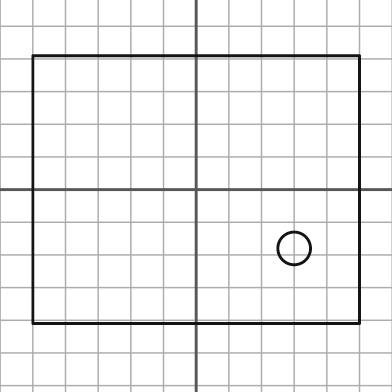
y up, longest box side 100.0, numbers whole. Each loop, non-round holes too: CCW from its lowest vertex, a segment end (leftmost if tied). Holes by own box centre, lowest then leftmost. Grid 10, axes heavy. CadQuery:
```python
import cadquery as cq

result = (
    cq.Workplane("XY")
    .moveTo(-50.0, -41.0)
    .lineTo(50.0, -41.0)
    .lineTo(50.0, 41.0)
    .lineTo(-50.0, 41.0)
    .close()
    .moveTo(30.0, -18.0)
    .circle(5.0)
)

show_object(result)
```